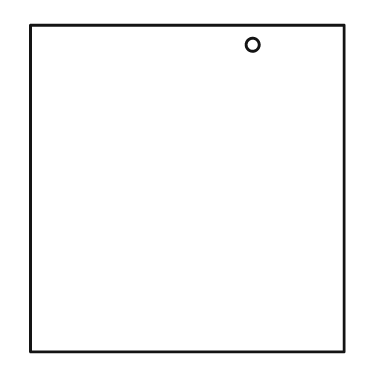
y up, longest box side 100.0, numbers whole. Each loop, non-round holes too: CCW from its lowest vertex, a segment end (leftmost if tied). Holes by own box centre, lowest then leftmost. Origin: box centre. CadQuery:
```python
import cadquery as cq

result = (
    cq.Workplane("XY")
    .moveTo(-48.0, -50.0)
    .lineTo(48.0, -50.0)
    .lineTo(48.0, 50.0)
    .lineTo(-48.0, 50.0)
    .close()
    .moveTo(20.0, 44.0)
    .circle(2.0)
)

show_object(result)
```